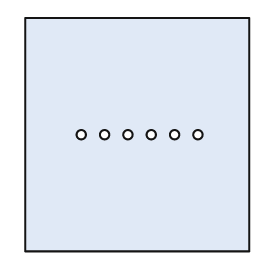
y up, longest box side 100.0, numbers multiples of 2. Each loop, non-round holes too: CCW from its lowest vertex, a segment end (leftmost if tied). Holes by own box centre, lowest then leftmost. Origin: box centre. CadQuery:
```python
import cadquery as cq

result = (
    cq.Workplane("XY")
    .moveTo(-48.0, -50.0)
    .lineTo(48.0, -50.0)
    .lineTo(48.0, 50.0)
    .lineTo(-48.0, 50.0)
    .close()
    .moveTo(-24.0, 0.0)
    .circle(2.0)
    .moveTo(-14.0, 0.0)
    .circle(2.0)
    .moveTo(-4.0, 0.0)
    .circle(2.0)
    .moveTo(6.0, 0.0)
    .circle(2.0)
    .moveTo(16.0, 0.0)
    .circle(2.0)
    .moveTo(26.0, 0.0)
    .circle(2.0)
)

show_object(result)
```